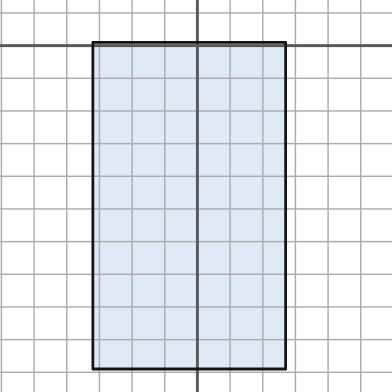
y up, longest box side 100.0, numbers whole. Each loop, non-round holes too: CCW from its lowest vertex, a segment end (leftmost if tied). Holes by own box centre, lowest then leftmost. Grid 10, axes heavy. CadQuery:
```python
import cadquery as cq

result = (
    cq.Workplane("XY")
    .moveTo(-32.0, -99.0)
    .lineTo(27.0, -99.0)
    .lineTo(27.0, 1.0)
    .lineTo(-32.0, 1.0)
    .close()
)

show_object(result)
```